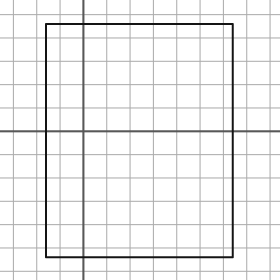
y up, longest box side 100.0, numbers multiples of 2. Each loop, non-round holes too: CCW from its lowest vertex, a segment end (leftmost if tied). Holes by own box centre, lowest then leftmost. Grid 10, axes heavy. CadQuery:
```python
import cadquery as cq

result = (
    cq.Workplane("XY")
    .moveTo(-16.0, -54.0)
    .lineTo(64.0, -54.0)
    .lineTo(64.0, 46.0)
    .lineTo(-16.0, 46.0)
    .close()
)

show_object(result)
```